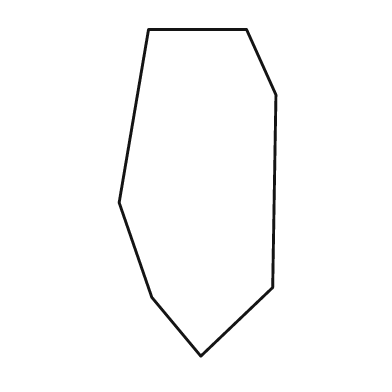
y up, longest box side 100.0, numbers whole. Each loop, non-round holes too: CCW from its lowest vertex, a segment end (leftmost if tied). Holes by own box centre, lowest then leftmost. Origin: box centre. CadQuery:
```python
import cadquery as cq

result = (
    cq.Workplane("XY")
    .moveTo(1.0, -50.0)
    .lineTo(23.0, -29.0)
    .lineTo(24.0, 30.0)
    .lineTo(15.0, 50.0)
    .lineTo(-15.0, 50.0)
    .lineTo(-24.0, -3.0)
    .lineTo(-14.0, -32.0)
    .close()
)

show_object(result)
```